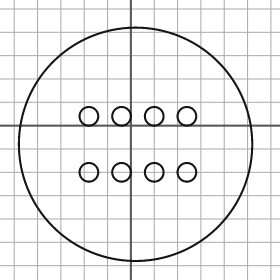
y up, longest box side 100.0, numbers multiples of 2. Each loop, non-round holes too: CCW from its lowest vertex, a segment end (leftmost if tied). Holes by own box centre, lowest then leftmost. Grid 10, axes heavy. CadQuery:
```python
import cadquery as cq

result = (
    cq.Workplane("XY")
    .moveTo(2.0, -8.0)
    .circle(50.0)
    .moveTo(-18.0, -20.0)
    .circle(4.0)
    .moveTo(-4.0, -20.0)
    .circle(4.0)
    .moveTo(10.0, -20.0)
    .circle(4.0)
    .moveTo(24.0, -20.0)
    .circle(4.0)
    .moveTo(-18.0, 4.0)
    .circle(4.0)
    .moveTo(-4.0, 4.0)
    .circle(4.0)
    .moveTo(10.0, 4.0)
    .circle(4.0)
    .moveTo(24.0, 4.0)
    .circle(4.0)
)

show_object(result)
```